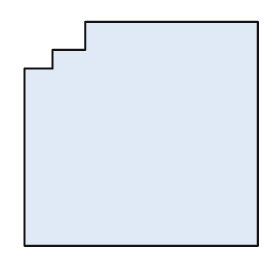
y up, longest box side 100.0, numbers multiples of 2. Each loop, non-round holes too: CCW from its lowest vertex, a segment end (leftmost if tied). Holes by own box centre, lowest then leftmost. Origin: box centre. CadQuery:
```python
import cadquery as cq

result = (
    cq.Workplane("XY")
    .moveTo(-50.0, -48.0)
    .lineTo(50.0, -48.0)
    .lineTo(50.0, 48.0)
    .lineTo(-24.0, 48.0)
    .lineTo(-24.0, 36.0)
    .lineTo(-38.0, 36.0)
    .lineTo(-38.0, 28.0)
    .lineTo(-50.0, 28.0)
    .close()
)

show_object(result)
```